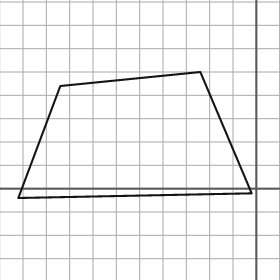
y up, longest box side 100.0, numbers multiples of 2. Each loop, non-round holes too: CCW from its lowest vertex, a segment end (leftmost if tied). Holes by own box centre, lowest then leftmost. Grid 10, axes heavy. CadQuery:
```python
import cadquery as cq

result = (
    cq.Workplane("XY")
    .moveTo(-102.0, -4.0)
    .lineTo(-2.0, -2.0)
    .lineTo(-24.0, 50.0)
    .lineTo(-84.0, 44.0)
    .close()
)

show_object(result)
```